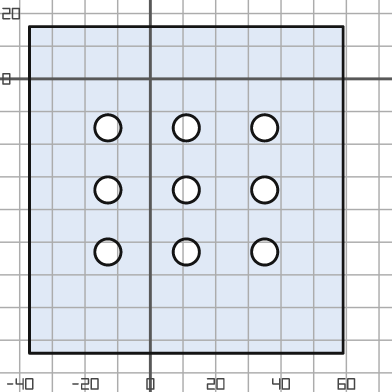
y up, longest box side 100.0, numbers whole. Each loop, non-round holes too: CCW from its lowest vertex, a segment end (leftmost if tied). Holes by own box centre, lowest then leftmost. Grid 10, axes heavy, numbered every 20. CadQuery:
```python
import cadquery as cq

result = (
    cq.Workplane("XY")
    .moveTo(-37.0, -84.0)
    .lineTo(59.0, -84.0)
    .lineTo(59.0, 16.0)
    .lineTo(-37.0, 16.0)
    .close()
    .moveTo(-13.0, -53.0)
    .circle(4.0)
    .moveTo(11.0, -53.0)
    .circle(4.0)
    .moveTo(35.0, -53.0)
    .circle(4.0)
    .moveTo(-13.0, -34.0)
    .circle(4.0)
    .moveTo(11.0, -34.0)
    .circle(4.0)
    .moveTo(35.0, -34.0)
    .circle(4.0)
    .moveTo(-13.0, -15.0)
    .circle(4.0)
    .moveTo(11.0, -15.0)
    .circle(4.0)
    .moveTo(35.0, -15.0)
    .circle(4.0)
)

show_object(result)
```